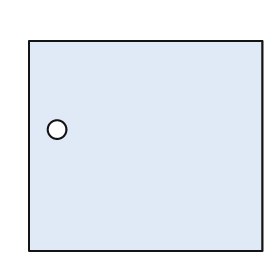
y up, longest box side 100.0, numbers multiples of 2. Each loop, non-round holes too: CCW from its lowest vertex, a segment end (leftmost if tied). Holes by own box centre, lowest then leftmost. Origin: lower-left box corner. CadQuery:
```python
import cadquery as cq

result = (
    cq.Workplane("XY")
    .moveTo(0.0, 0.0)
    .lineTo(100.0, 0.0)
    .lineTo(100.0, 90.0)
    .lineTo(0.0, 90.0)
    .close()
    .moveTo(12.0, 52.0)
    .circle(4.0)
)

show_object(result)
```